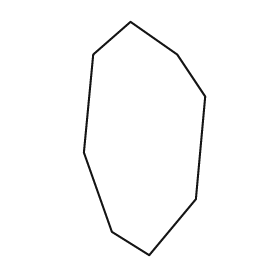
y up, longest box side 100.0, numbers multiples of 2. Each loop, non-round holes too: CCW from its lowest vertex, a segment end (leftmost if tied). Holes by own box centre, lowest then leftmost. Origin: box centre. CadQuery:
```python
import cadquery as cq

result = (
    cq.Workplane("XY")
    .moveTo(2.0, -50.0)
    .lineTo(22.0, -26.0)
    .lineTo(26.0, 18.0)
    .lineTo(14.0, 36.0)
    .lineTo(-6.0, 50.0)
    .lineTo(-22.0, 36.0)
    .lineTo(-26.0, -6.0)
    .lineTo(-14.0, -40.0)
    .close()
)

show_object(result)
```